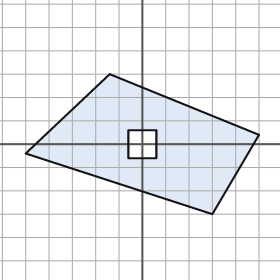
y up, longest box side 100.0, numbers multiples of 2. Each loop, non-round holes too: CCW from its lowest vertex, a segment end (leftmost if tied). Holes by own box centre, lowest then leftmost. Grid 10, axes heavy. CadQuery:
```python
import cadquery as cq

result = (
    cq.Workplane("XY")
    .moveTo(30.0, -30.0)
    .lineTo(50.0, 4.0)
    .lineTo(-14.0, 30.0)
    .lineTo(-50.0, -4.0)
    .close()
    .moveTo(-6.0, -6.0)
    .lineTo(6.0, -6.0)
    .lineTo(6.0, 6.0)
    .lineTo(-6.0, 6.0)
    .close()
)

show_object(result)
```